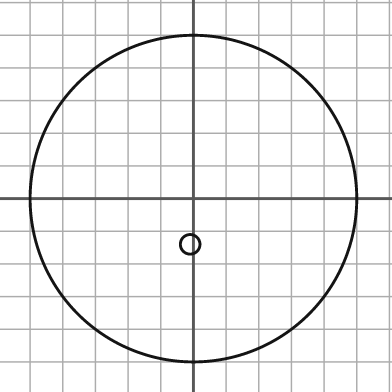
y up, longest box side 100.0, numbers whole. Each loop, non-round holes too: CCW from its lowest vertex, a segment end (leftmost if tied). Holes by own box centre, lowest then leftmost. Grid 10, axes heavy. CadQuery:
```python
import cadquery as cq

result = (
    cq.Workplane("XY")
    .moveTo(0.0, 0.0)
    .circle(50.0)
    .moveTo(-1.0, -14.0)
    .circle(3.0)
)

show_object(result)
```